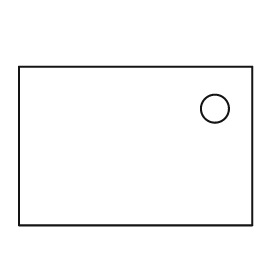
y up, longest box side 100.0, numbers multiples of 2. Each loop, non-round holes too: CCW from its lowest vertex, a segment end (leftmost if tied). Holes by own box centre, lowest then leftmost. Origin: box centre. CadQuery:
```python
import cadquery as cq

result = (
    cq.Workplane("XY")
    .moveTo(-50.0, -34.0)
    .lineTo(50.0, -34.0)
    .lineTo(50.0, 34.0)
    .lineTo(-50.0, 34.0)
    .close()
    .moveTo(34.0, 16.0)
    .circle(6.0)
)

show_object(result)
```